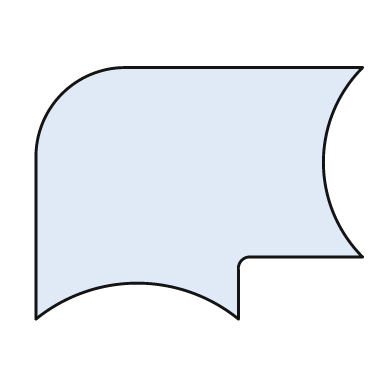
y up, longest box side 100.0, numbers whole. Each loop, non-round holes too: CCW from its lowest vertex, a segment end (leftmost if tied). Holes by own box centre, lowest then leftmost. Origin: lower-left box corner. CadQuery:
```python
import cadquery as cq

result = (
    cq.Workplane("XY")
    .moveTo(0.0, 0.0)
    .threePointArc((31.0, 11.0), (62.0, 0.0))
    .lineTo(62.0, 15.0)
    .threePointArc((63.0, 18.0), (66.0, 19.0))
    .lineTo(100.0, 19.0)
    .threePointArc((88.0, 48.0), (100.0, 77.0))
    .lineTo(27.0, 77.0)
    .threePointArc((8.0, 69.0), (0.0, 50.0))
    .close()
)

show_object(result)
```